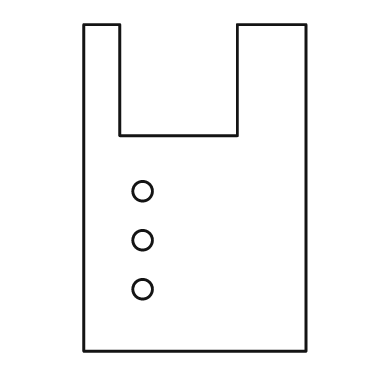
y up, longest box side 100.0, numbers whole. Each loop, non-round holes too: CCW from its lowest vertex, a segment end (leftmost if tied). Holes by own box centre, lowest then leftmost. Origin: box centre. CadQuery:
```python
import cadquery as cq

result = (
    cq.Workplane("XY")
    .moveTo(-34.0, -50.0)
    .lineTo(34.0, -50.0)
    .lineTo(34.0, 50.0)
    .lineTo(13.0, 50.0)
    .lineTo(13.0, 16.0)
    .lineTo(-23.0, 16.0)
    .lineTo(-23.0, 50.0)
    .lineTo(-34.0, 50.0)
    .close()
    .moveTo(-16.0, -31.0)
    .circle(3.0)
    .moveTo(-16.0, -16.0)
    .circle(3.0)
    .moveTo(-16.0, -1.0)
    .circle(3.0)
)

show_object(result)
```